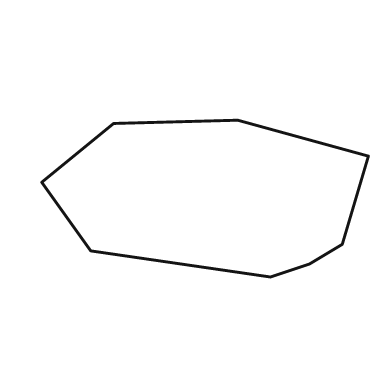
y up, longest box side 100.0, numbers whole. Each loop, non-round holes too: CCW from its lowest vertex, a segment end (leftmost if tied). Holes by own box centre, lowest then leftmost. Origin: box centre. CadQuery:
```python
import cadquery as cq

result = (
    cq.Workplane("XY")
    .moveTo(20.0, -24.0)
    .lineTo(32.0, -20.0)
    .lineTo(42.0, -14.0)
    .lineTo(50.0, 13.0)
    .lineTo(10.0, 24.0)
    .lineTo(-28.0, 23.0)
    .lineTo(-50.0, 5.0)
    .lineTo(-35.0, -16.0)
    .close()
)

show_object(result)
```